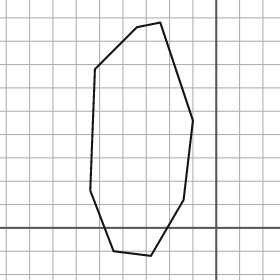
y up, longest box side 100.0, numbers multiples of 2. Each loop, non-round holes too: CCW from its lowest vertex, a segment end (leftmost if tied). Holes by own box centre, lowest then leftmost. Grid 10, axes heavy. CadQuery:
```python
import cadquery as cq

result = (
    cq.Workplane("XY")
    .moveTo(-28.0, -12.0)
    .lineTo(-14.0, 12.0)
    .lineTo(-10.0, 46.0)
    .lineTo(-24.0, 88.0)
    .lineTo(-34.0, 86.0)
    .lineTo(-52.0, 68.0)
    .lineTo(-54.0, 16.0)
    .lineTo(-44.0, -10.0)
    .close()
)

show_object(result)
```